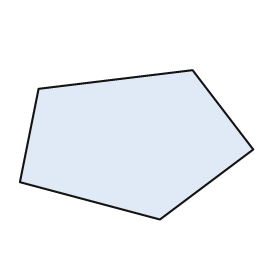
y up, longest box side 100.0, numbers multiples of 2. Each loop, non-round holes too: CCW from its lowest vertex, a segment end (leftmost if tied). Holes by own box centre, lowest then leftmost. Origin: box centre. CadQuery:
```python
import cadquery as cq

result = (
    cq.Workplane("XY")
    .moveTo(10.0, -32.0)
    .lineTo(50.0, -2.0)
    .lineTo(24.0, 32.0)
    .lineTo(-42.0, 24.0)
    .lineTo(-50.0, -16.0)
    .close()
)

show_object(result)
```